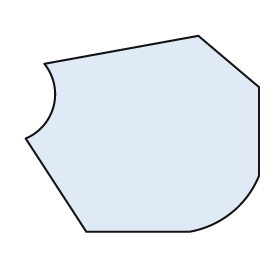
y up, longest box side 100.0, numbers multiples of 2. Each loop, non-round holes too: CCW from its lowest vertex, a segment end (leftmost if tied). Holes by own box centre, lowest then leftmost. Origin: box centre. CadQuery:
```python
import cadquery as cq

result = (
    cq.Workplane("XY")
    .moveTo(-24.0, -42.0)
    .lineTo(20.0, -42.0)
    .threePointArc((38.0, -34.0), (50.0, -18.0))
    .lineTo(50.0, 20.0)
    .lineTo(24.0, 42.0)
    .lineTo(-42.0, 30.0)
    .threePointArc((-38.0, 12.0), (-50.0, -2.0))
    .close()
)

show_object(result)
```